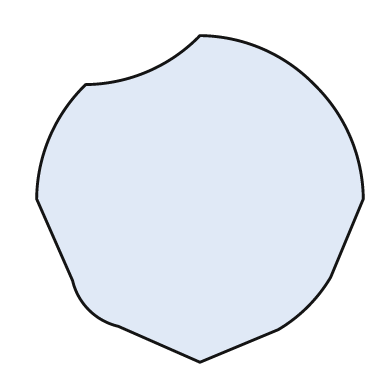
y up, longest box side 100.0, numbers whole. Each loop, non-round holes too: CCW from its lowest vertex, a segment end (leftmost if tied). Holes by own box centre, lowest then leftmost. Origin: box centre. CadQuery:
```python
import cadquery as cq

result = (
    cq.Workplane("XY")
    .moveTo(0.0, -50.0)
    .lineTo(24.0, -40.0)
    .threePointArc((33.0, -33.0), (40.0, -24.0))
    .lineTo(50.0, 0.0)
    .threePointArc((46.0, 19.0), (35.0, 35.0))
    .threePointArc((19.0, 46.0), (0.0, 50.0))
    .threePointArc((-16.0, 39.0), (-35.0, 35.0))
    .threePointArc((-46.0, 19.0), (-50.0, 0.0))
    .lineTo(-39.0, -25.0)
    .threePointArc((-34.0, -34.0), (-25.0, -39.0))
    .close()
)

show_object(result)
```